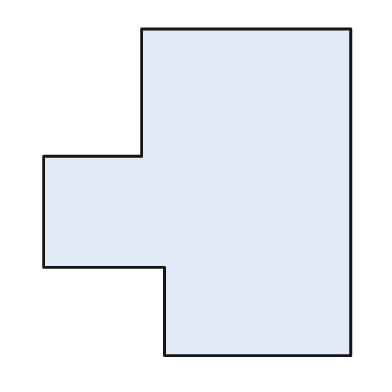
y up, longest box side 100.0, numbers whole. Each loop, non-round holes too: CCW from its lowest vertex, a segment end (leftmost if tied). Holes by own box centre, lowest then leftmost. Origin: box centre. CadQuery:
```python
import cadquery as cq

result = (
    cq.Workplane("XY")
    .moveTo(-10.0, -50.0)
    .lineTo(47.0, -50.0)
    .lineTo(47.0, 50.0)
    .lineTo(-17.0, 50.0)
    .lineTo(-17.0, 11.0)
    .lineTo(-47.0, 11.0)
    .lineTo(-47.0, -23.0)
    .lineTo(-10.0, -23.0)
    .close()
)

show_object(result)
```